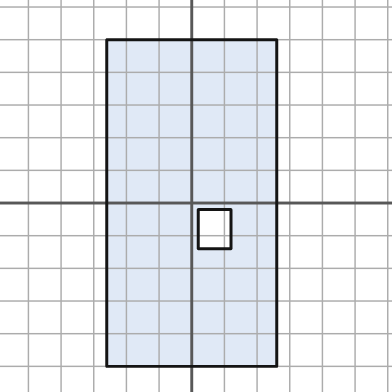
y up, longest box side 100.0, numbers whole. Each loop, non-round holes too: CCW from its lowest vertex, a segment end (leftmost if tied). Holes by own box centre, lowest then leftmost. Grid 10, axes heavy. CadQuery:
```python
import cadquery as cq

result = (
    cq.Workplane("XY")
    .moveTo(-26.0, -50.0)
    .lineTo(26.0, -50.0)
    .lineTo(26.0, 50.0)
    .lineTo(-26.0, 50.0)
    .close()
    .moveTo(2.0, -14.0)
    .lineTo(12.0, -14.0)
    .lineTo(12.0, -2.0)
    .lineTo(2.0, -2.0)
    .close()
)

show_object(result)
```